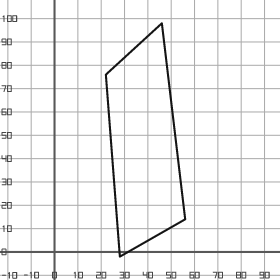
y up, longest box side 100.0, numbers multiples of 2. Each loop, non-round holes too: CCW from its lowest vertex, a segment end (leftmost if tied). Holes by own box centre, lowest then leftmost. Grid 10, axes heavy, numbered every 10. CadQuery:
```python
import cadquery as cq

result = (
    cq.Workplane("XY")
    .moveTo(28.0, -2.0)
    .lineTo(56.0, 14.0)
    .lineTo(46.0, 98.0)
    .lineTo(22.0, 76.0)
    .close()
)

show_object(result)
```